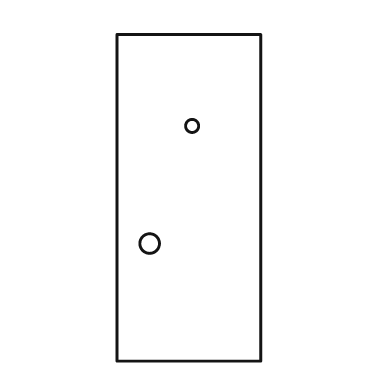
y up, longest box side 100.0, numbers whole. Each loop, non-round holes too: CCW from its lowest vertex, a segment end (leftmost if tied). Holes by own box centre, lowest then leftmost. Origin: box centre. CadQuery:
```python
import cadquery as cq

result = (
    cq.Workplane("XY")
    .moveTo(-22.0, -50.0)
    .lineTo(22.0, -50.0)
    .lineTo(22.0, 50.0)
    .lineTo(-22.0, 50.0)
    .close()
    .moveTo(-12.0, -14.0)
    .circle(3.0)
    .moveTo(1.0, 22.0)
    .circle(2.0)
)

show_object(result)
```